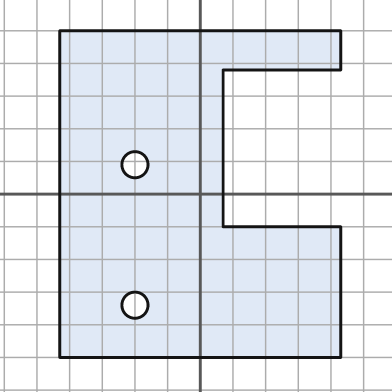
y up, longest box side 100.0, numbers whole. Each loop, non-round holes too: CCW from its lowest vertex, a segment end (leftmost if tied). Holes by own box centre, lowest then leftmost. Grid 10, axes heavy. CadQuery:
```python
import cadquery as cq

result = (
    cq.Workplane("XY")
    .moveTo(-43.0, -50.0)
    .lineTo(43.0, -50.0)
    .lineTo(43.0, -10.0)
    .lineTo(7.0, -10.0)
    .lineTo(7.0, 38.0)
    .lineTo(43.0, 38.0)
    .lineTo(43.0, 50.0)
    .lineTo(-43.0, 50.0)
    .close()
    .moveTo(-20.0, -34.0)
    .circle(4.0)
    .moveTo(-20.0, 9.0)
    .circle(4.0)
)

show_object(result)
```